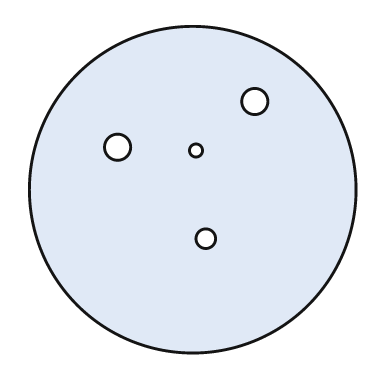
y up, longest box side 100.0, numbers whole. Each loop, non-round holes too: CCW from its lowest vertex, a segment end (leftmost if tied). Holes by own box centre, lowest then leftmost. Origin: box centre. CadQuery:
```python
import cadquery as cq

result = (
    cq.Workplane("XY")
    .moveTo(0.0, 0.0)
    .circle(50.0)
    .moveTo(4.0, -15.0)
    .circle(3.0)
    .moveTo(1.0, 12.0)
    .circle(2.0)
    .moveTo(-23.0, 13.0)
    .circle(4.0)
    .moveTo(19.0, 27.0)
    .circle(4.0)
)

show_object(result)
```